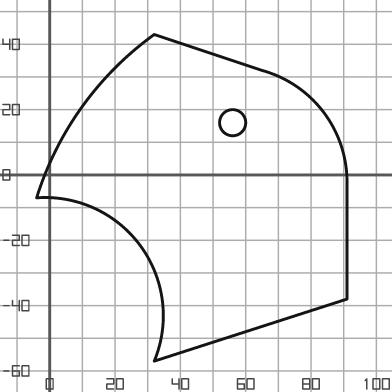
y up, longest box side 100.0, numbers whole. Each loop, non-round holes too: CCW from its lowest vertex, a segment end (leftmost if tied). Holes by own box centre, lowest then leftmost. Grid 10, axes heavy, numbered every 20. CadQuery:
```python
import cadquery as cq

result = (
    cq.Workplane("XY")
    .moveTo(32.0, -57.0)
    .lineTo(91.0, -38.0)
    .lineTo(91.0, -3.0)
    .threePointArc((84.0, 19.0), (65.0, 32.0))
    .lineTo(32.0, 43.0)
    .threePointArc((10.0, 21.0), (-4.0, -7.0))
    .threePointArc((28.0, -22.0), (32.0, -57.0))
    .close()
    .moveTo(56.0, 16.0)
    .circle(4.0)
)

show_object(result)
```